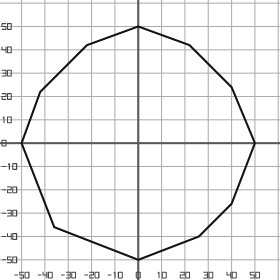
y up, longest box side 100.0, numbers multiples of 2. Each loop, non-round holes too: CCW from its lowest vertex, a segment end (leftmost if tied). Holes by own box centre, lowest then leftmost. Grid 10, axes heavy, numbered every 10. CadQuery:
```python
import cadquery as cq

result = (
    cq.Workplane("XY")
    .moveTo(0.0, -50.0)
    .lineTo(26.0, -40.0)
    .lineTo(40.0, -26.0)
    .lineTo(50.0, 0.0)
    .lineTo(40.0, 24.0)
    .lineTo(22.0, 42.0)
    .lineTo(0.0, 50.0)
    .lineTo(-22.0, 42.0)
    .lineTo(-42.0, 22.0)
    .lineTo(-50.0, 0.0)
    .lineTo(-36.0, -36.0)
    .close()
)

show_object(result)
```